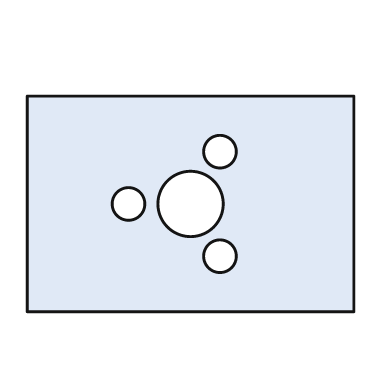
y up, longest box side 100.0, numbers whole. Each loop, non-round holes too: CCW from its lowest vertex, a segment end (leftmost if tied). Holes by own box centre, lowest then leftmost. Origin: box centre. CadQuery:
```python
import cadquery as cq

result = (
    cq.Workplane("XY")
    .moveTo(-50.0, -33.0)
    .lineTo(50.0, -33.0)
    .lineTo(50.0, 33.0)
    .lineTo(-50.0, 33.0)
    .close()
    .moveTo(9.0, -16.0)
    .circle(5.0)
    .moveTo(-19.0, 0.0)
    .circle(5.0)
    .moveTo(0.0, 0.0)
    .circle(10.0)
    .moveTo(9.0, 16.0)
    .circle(5.0)
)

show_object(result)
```